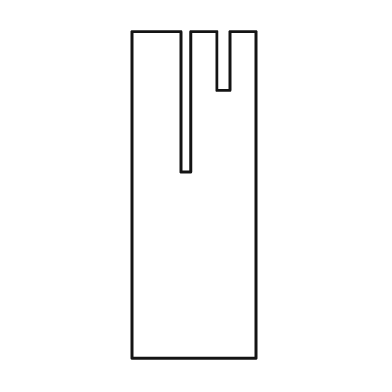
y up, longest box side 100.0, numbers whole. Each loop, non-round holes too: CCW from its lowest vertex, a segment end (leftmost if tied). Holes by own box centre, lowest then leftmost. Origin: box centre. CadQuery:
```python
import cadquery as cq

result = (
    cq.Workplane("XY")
    .moveTo(-19.0, -50.0)
    .lineTo(19.0, -50.0)
    .lineTo(19.0, 50.0)
    .lineTo(11.0, 50.0)
    .lineTo(11.0, 32.0)
    .lineTo(7.0, 32.0)
    .lineTo(7.0, 50.0)
    .lineTo(-1.0, 50.0)
    .lineTo(-1.0, 7.0)
    .lineTo(-4.0, 7.0)
    .lineTo(-4.0, 50.0)
    .lineTo(-19.0, 50.0)
    .close()
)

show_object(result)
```